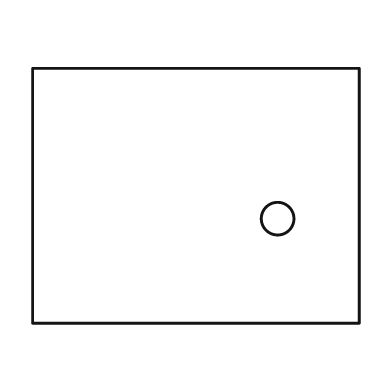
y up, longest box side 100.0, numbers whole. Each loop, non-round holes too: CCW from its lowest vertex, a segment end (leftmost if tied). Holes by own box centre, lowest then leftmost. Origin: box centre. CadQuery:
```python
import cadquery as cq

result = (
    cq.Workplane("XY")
    .moveTo(-50.0, -39.0)
    .lineTo(50.0, -39.0)
    .lineTo(50.0, 39.0)
    .lineTo(-50.0, 39.0)
    .close()
    .moveTo(25.0, -7.0)
    .circle(5.0)
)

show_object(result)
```